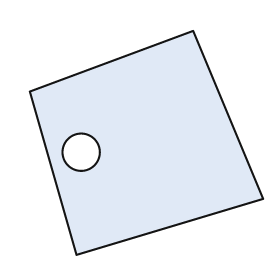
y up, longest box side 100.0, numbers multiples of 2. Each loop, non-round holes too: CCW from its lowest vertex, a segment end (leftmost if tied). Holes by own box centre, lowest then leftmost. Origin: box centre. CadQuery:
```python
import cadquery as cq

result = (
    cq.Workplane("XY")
    .moveTo(-30.0, -48.0)
    .lineTo(50.0, -24.0)
    .lineTo(20.0, 48.0)
    .lineTo(-50.0, 22.0)
    .close()
    .moveTo(-28.0, -4.0)
    .circle(8.0)
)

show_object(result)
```